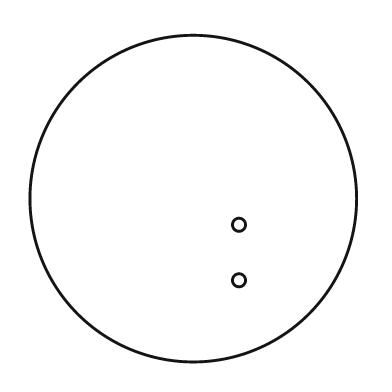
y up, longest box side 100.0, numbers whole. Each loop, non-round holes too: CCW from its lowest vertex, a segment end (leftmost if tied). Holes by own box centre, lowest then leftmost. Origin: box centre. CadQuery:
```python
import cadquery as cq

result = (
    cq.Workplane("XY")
    .moveTo(0.0, 0.0)
    .circle(50.0)
    .moveTo(14.0, -25.0)
    .circle(2.0)
    .moveTo(14.0, -8.0)
    .circle(2.0)
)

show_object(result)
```